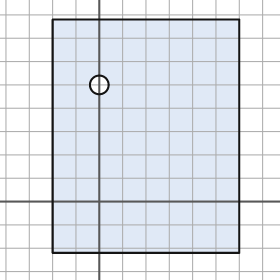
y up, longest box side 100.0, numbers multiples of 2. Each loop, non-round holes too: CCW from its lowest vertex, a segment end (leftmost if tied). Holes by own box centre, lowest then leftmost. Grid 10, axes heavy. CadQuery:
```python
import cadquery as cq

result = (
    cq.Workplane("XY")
    .moveTo(-20.0, -22.0)
    .lineTo(60.0, -22.0)
    .lineTo(60.0, 78.0)
    .lineTo(-20.0, 78.0)
    .close()
    .moveTo(0.0, 50.0)
    .circle(4.0)
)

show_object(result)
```